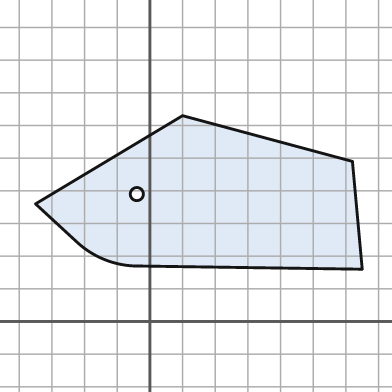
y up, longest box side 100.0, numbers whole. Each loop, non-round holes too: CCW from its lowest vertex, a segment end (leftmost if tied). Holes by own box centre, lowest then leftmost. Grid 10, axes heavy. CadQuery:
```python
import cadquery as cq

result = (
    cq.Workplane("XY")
    .moveTo(65.0, 16.0)
    .lineTo(62.0, 49.0)
    .lineTo(10.0, 63.0)
    .lineTo(-35.0, 36.0)
    .lineTo(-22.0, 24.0)
    .threePointArc((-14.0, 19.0), (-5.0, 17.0))
    .close()
    .moveTo(-4.0, 39.0)
    .circle(2.0)
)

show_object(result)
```